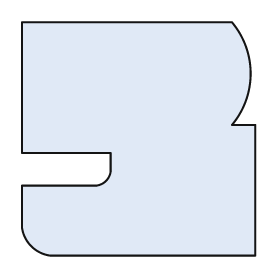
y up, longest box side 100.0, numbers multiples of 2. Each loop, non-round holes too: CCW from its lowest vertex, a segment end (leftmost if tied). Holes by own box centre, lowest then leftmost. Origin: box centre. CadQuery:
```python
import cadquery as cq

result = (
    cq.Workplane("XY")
    .moveTo(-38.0, -50.0)
    .lineTo(50.0, -50.0)
    .lineTo(50.0, 6.0)
    .lineTo(40.0, 6.0)
    .threePointArc((48.0, 28.0), (40.0, 50.0))
    .lineTo(-50.0, 50.0)
    .lineTo(-50.0, -6.0)
    .lineTo(-12.0, -6.0)
    .lineTo(-12.0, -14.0)
    .threePointArc((-14.0, -18.0), (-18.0, -20.0))
    .lineTo(-50.0, -20.0)
    .lineTo(-50.0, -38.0)
    .threePointArc((-46.0, -46.0), (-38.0, -50.0))
    .close()
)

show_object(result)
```